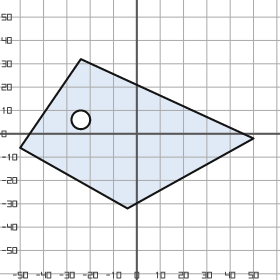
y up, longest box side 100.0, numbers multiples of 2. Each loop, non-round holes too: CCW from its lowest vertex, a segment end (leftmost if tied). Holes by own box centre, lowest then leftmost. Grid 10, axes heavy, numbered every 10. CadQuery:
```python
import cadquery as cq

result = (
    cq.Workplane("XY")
    .moveTo(-4.0, -32.0)
    .lineTo(50.0, -2.0)
    .lineTo(-24.0, 32.0)
    .lineTo(-50.0, -6.0)
    .close()
    .moveTo(-24.0, 6.0)
    .circle(4.0)
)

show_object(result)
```